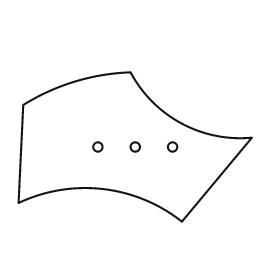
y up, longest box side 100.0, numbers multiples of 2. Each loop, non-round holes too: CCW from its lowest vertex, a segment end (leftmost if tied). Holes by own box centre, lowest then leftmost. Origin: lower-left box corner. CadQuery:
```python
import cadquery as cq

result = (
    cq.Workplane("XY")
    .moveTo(70.0, 0.0)
    .lineTo(100.0, 36.0)
    .threePointArc((70.0, 42.0), (48.0, 64.0))
    .threePointArc((24.0, 60.0), (2.0, 50.0))
    .lineTo(0.0, 8.0)
    .threePointArc((36.0, 14.0), (70.0, 0.0))
    .close()
    .moveTo(34.0, 32.0)
    .circle(2.0)
    .moveTo(50.0, 32.0)
    .circle(2.0)
    .moveTo(66.0, 32.0)
    .circle(2.0)
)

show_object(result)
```